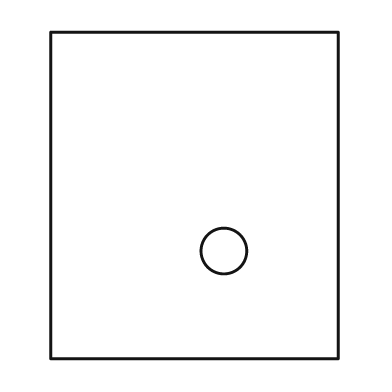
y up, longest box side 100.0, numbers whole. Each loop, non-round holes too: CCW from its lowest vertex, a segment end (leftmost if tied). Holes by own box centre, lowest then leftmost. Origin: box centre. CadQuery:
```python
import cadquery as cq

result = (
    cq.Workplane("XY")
    .moveTo(-44.0, -50.0)
    .lineTo(44.0, -50.0)
    .lineTo(44.0, 50.0)
    .lineTo(-44.0, 50.0)
    .close()
    .moveTo(9.0, -17.0)
    .circle(7.0)
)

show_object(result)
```